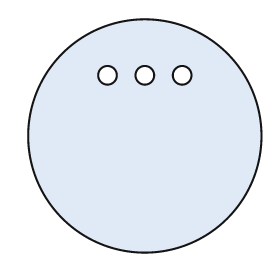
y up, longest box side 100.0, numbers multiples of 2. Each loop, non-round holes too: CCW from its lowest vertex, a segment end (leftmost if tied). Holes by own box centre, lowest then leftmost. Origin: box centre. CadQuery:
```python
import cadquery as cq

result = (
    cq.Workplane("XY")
    .moveTo(0.0, 0.0)
    .circle(50.0)
    .moveTo(-16.0, 26.0)
    .circle(4.0)
    .moveTo(0.0, 26.0)
    .circle(4.0)
    .moveTo(16.0, 26.0)
    .circle(4.0)
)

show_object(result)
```